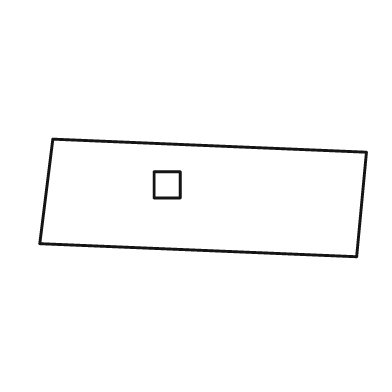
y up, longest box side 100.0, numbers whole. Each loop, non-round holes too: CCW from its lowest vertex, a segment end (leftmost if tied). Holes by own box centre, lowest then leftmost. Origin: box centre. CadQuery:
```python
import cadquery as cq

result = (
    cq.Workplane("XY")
    .moveTo(47.0, -18.0)
    .lineTo(50.0, 14.0)
    .lineTo(-46.0, 18.0)
    .lineTo(-50.0, -14.0)
    .close()
    .moveTo(-15.0, 0.0)
    .lineTo(-7.0, 0.0)
    .lineTo(-7.0, 8.0)
    .lineTo(-15.0, 8.0)
    .close()
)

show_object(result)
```